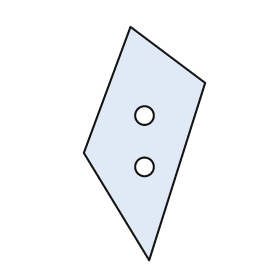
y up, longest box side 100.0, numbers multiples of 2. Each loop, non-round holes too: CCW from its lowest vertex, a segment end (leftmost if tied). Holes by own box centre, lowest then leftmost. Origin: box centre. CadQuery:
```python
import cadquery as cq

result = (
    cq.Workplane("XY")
    .moveTo(2.0, -50.0)
    .lineTo(26.0, 26.0)
    .lineTo(-6.0, 50.0)
    .lineTo(-26.0, -4.0)
    .close()
    .moveTo(0.0, -10.0)
    .circle(4.0)
    .moveTo(0.0, 12.0)
    .circle(4.0)
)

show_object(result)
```